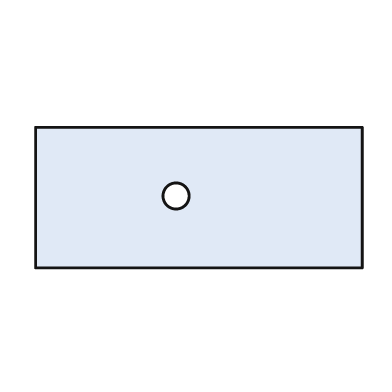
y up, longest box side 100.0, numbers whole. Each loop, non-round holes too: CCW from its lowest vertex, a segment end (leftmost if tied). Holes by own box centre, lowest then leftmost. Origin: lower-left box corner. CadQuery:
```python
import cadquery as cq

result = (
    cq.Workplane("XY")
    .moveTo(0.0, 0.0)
    .lineTo(100.0, 0.0)
    .lineTo(100.0, 43.0)
    .lineTo(0.0, 43.0)
    .close()
    .moveTo(43.0, 22.0)
    .circle(4.0)
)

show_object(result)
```